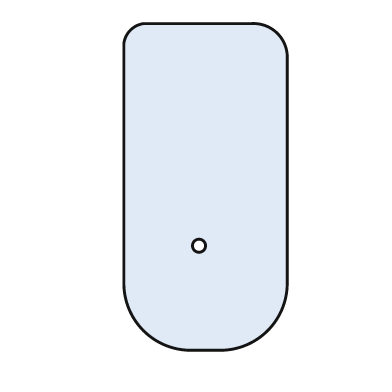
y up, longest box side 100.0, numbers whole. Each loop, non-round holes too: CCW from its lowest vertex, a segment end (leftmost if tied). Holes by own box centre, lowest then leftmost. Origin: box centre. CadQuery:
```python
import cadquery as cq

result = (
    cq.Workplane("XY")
    .moveTo(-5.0, -50.0)
    .lineTo(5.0, -50.0)
    .threePointArc((19.0, -44.0), (25.0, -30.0))
    .lineTo(25.0, 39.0)
    .threePointArc((22.0, 47.0), (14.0, 50.0))
    .lineTo(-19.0, 50.0)
    .threePointArc((-23.0, 48.0), (-25.0, 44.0))
    .lineTo(-25.0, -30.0)
    .threePointArc((-19.0, -44.0), (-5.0, -50.0))
    .close()
    .moveTo(-2.0, -18.0)
    .circle(2.0)
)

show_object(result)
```